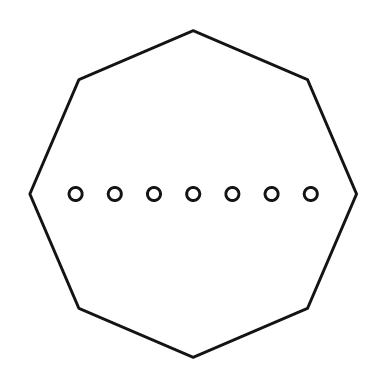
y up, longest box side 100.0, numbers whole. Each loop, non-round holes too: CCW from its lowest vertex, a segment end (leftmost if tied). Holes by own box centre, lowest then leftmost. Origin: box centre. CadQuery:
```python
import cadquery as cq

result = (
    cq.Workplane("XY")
    .moveTo(0.0, -50.0)
    .lineTo(35.0, -35.0)
    .lineTo(50.0, 0.0)
    .lineTo(35.0, 35.0)
    .lineTo(0.0, 50.0)
    .lineTo(-35.0, 35.0)
    .lineTo(-50.0, 0.0)
    .lineTo(-35.0, -35.0)
    .close()
    .moveTo(-36.0, 0.0)
    .circle(2.0)
    .moveTo(-24.0, 0.0)
    .circle(2.0)
    .moveTo(-12.0, 0.0)
    .circle(2.0)
    .moveTo(0.0, 0.0)
    .circle(2.0)
    .moveTo(12.0, 0.0)
    .circle(2.0)
    .moveTo(24.0, 0.0)
    .circle(2.0)
    .moveTo(36.0, 0.0)
    .circle(2.0)
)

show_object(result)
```